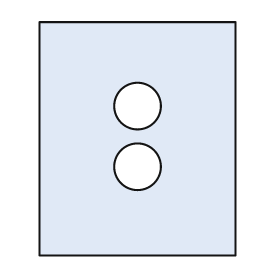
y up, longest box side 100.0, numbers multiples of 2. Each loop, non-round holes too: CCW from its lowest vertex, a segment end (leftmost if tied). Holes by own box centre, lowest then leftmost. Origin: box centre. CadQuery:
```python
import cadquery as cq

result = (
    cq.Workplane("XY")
    .moveTo(-42.0, -50.0)
    .lineTo(42.0, -50.0)
    .lineTo(42.0, 50.0)
    .lineTo(-42.0, 50.0)
    .close()
    .moveTo(0.0, -12.0)
    .circle(10.0)
    .moveTo(0.0, 14.0)
    .circle(10.0)
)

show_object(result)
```